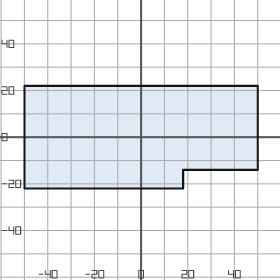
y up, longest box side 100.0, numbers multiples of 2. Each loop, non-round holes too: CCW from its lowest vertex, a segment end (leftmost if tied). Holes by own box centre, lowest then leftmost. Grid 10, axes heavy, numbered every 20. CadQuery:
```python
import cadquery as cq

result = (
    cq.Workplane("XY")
    .moveTo(-50.0, -22.0)
    .lineTo(18.0, -22.0)
    .lineTo(18.0, -14.0)
    .lineTo(50.0, -14.0)
    .lineTo(50.0, 22.0)
    .lineTo(-50.0, 22.0)
    .close()
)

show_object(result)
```